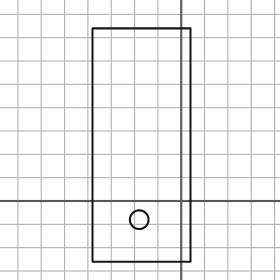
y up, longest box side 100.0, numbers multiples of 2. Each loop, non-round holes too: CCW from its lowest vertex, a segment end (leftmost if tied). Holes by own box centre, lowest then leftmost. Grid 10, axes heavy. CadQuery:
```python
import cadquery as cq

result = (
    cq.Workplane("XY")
    .moveTo(-38.0, -26.0)
    .lineTo(4.0, -26.0)
    .lineTo(4.0, 74.0)
    .lineTo(-38.0, 74.0)
    .close()
    .moveTo(-18.0, -8.0)
    .circle(4.0)
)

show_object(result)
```